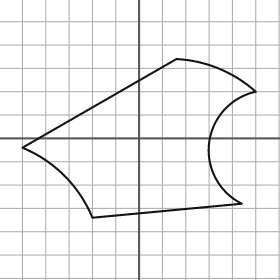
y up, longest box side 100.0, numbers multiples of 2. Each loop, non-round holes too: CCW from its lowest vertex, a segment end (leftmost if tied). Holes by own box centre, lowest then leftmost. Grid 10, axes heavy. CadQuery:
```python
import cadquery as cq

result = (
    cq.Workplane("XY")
    .moveTo(-20.0, -34.0)
    .lineTo(44.0, -28.0)
    .threePointArc((30.0, -2.0), (50.0, 20.0))
    .threePointArc((34.0, 30.0), (16.0, 34.0))
    .lineTo(-50.0, -4.0)
    .threePointArc((-32.0, -16.0), (-20.0, -34.0))
    .close()
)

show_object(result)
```